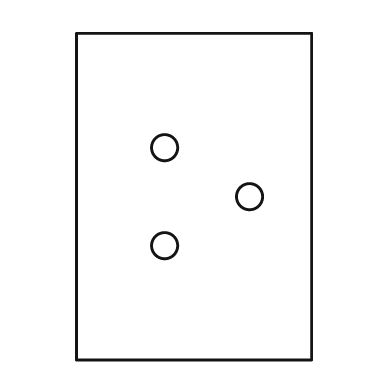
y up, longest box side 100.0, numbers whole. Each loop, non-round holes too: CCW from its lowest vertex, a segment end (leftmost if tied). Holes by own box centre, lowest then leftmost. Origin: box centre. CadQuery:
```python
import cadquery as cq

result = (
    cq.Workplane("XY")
    .moveTo(-36.0, -50.0)
    .lineTo(36.0, -50.0)
    .lineTo(36.0, 50.0)
    .lineTo(-36.0, 50.0)
    .close()
    .moveTo(-9.0, -15.0)
    .circle(4.0)
    .moveTo(17.0, 0.0)
    .circle(4.0)
    .moveTo(-9.0, 15.0)
    .circle(4.0)
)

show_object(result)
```